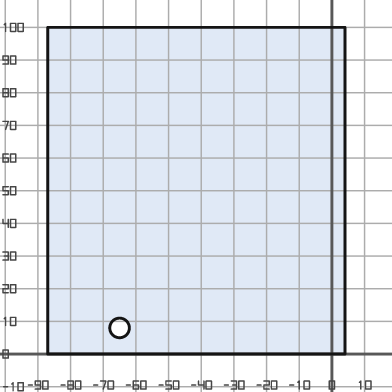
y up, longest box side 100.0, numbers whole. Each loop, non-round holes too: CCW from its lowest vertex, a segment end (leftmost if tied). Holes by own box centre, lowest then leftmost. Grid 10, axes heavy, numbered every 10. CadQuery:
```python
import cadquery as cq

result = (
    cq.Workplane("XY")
    .moveTo(-87.0, 0.0)
    .lineTo(4.0, 0.0)
    .lineTo(4.0, 100.0)
    .lineTo(-87.0, 100.0)
    .close()
    .moveTo(-65.0, 8.0)
    .circle(3.0)
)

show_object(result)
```